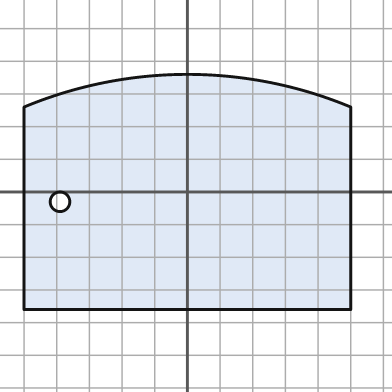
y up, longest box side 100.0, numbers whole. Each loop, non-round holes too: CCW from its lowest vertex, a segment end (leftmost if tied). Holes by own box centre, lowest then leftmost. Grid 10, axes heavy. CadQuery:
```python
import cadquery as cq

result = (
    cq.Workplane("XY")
    .moveTo(-50.0, -36.0)
    .lineTo(50.0, -36.0)
    .lineTo(50.0, 26.0)
    .threePointArc((0.0, 36.0), (-50.0, 26.0))
    .close()
    .moveTo(-39.0, -3.0)
    .circle(3.0)
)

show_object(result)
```